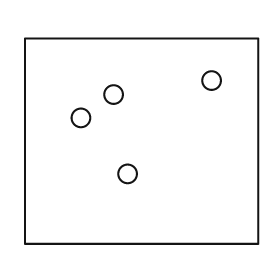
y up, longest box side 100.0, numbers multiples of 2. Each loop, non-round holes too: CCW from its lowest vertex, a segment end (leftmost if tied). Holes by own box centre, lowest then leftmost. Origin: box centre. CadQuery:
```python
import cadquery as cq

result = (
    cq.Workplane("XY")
    .moveTo(-50.0, -44.0)
    .lineTo(50.0, -44.0)
    .lineTo(50.0, 44.0)
    .lineTo(-50.0, 44.0)
    .close()
    .moveTo(-6.0, -14.0)
    .circle(4.0)
    .moveTo(-26.0, 10.0)
    .circle(4.0)
    .moveTo(-12.0, 20.0)
    .circle(4.0)
    .moveTo(30.0, 26.0)
    .circle(4.0)
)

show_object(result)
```